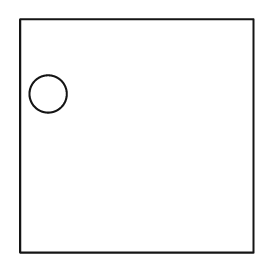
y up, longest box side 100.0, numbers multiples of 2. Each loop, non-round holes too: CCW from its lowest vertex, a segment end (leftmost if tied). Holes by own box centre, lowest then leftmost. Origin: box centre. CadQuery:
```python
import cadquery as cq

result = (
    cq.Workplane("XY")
    .moveTo(-50.0, -50.0)
    .lineTo(50.0, -50.0)
    .lineTo(50.0, 50.0)
    .lineTo(-50.0, 50.0)
    .close()
    .moveTo(-38.0, 18.0)
    .circle(8.0)
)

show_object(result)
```